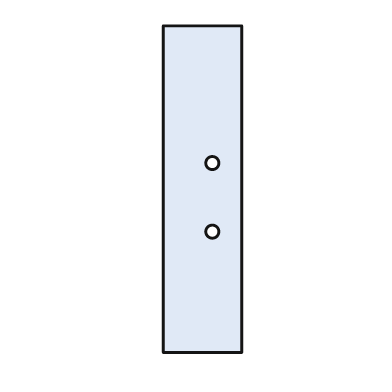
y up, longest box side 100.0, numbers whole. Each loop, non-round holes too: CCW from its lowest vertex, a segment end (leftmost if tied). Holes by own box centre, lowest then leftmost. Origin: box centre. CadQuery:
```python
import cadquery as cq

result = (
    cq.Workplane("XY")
    .moveTo(-12.0, -50.0)
    .lineTo(12.0, -50.0)
    .lineTo(12.0, 50.0)
    .lineTo(-12.0, 50.0)
    .close()
    .moveTo(3.0, -13.0)
    .circle(2.0)
    .moveTo(3.0, 8.0)
    .circle(2.0)
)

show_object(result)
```